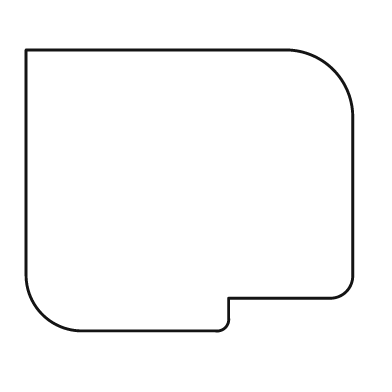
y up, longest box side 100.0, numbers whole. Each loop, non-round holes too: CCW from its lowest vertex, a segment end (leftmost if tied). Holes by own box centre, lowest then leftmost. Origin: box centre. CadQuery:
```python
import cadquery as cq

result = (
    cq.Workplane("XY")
    .moveTo(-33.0, -43.0)
    .lineTo(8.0, -43.0)
    .threePointArc((11.0, -42.0), (12.0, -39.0))
    .lineTo(12.0, -33.0)
    .lineTo(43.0, -33.0)
    .threePointArc((48.0, -31.0), (50.0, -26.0))
    .lineTo(50.0, 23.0)
    .threePointArc((44.0, 37.0), (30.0, 43.0))
    .lineTo(-50.0, 43.0)
    .lineTo(-50.0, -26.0)
    .threePointArc((-45.0, -38.0), (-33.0, -43.0))
    .close()
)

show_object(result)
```